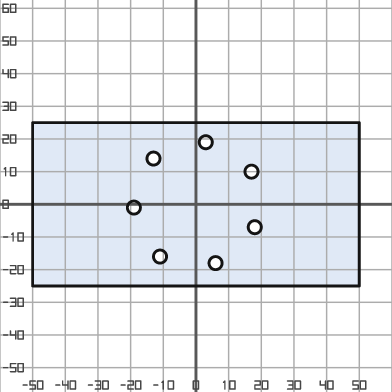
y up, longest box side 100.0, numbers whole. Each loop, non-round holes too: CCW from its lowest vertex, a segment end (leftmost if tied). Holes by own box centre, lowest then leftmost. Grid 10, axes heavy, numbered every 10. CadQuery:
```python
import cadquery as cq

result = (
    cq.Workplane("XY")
    .moveTo(-50.0, -25.0)
    .lineTo(50.0, -25.0)
    .lineTo(50.0, 25.0)
    .lineTo(-50.0, 25.0)
    .close()
    .moveTo(6.0, -18.0)
    .circle(2.0)
    .moveTo(-11.0, -16.0)
    .circle(2.0)
    .moveTo(18.0, -7.0)
    .circle(2.0)
    .moveTo(-19.0, -1.0)
    .circle(2.0)
    .moveTo(17.0, 10.0)
    .circle(2.0)
    .moveTo(-13.0, 14.0)
    .circle(2.0)
    .moveTo(3.0, 19.0)
    .circle(2.0)
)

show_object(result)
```